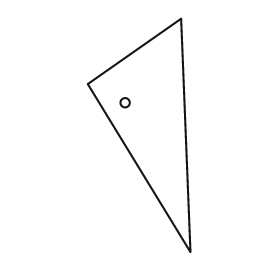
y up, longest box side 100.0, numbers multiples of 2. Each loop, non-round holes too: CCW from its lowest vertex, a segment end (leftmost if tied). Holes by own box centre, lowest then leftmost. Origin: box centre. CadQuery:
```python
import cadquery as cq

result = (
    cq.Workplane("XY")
    .moveTo(22.0, -50.0)
    .lineTo(18.0, 50.0)
    .lineTo(-22.0, 22.0)
    .close()
    .moveTo(-6.0, 14.0)
    .circle(2.0)
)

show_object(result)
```